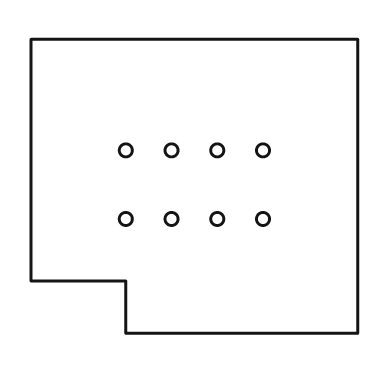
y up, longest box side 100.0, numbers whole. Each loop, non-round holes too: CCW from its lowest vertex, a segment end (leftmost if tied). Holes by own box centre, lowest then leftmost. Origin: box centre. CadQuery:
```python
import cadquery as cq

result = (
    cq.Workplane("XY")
    .moveTo(-21.0, -45.0)
    .lineTo(50.0, -45.0)
    .lineTo(50.0, 45.0)
    .lineTo(-50.0, 45.0)
    .lineTo(-50.0, -29.0)
    .lineTo(-21.0, -29.0)
    .close()
    .moveTo(-21.0, -10.0)
    .circle(2.0)
    .moveTo(-7.0, -10.0)
    .circle(2.0)
    .moveTo(7.0, -10.0)
    .circle(2.0)
    .moveTo(21.0, -10.0)
    .circle(2.0)
    .moveTo(-21.0, 11.0)
    .circle(2.0)
    .moveTo(-7.0, 11.0)
    .circle(2.0)
    .moveTo(7.0, 11.0)
    .circle(2.0)
    .moveTo(21.0, 11.0)
    .circle(2.0)
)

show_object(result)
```